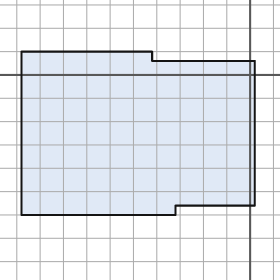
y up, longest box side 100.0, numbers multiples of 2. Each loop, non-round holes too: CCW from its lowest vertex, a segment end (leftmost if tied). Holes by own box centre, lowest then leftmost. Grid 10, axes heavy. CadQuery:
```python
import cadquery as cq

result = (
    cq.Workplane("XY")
    .moveTo(-98.0, -60.0)
    .lineTo(-32.0, -60.0)
    .lineTo(-32.0, -56.0)
    .lineTo(2.0, -56.0)
    .lineTo(2.0, 6.0)
    .lineTo(-42.0, 6.0)
    .lineTo(-42.0, 10.0)
    .lineTo(-98.0, 10.0)
    .close()
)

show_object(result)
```